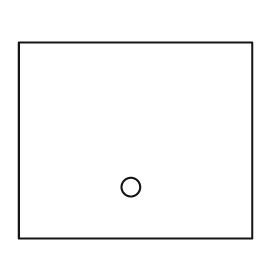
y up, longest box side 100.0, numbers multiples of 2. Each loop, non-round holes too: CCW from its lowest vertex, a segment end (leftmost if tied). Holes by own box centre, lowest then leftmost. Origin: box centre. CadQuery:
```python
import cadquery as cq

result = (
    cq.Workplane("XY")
    .moveTo(-50.0, -42.0)
    .lineTo(50.0, -42.0)
    .lineTo(50.0, 42.0)
    .lineTo(-50.0, 42.0)
    .close()
    .moveTo(-2.0, -20.0)
    .circle(4.0)
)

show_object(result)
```